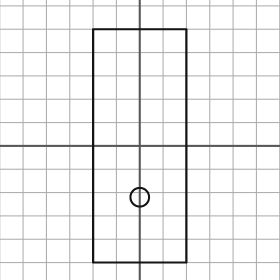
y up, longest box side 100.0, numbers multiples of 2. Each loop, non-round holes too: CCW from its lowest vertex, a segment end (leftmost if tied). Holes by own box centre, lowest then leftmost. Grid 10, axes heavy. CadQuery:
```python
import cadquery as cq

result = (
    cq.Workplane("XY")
    .moveTo(-20.0, -50.0)
    .lineTo(20.0, -50.0)
    .lineTo(20.0, 50.0)
    .lineTo(-20.0, 50.0)
    .close()
    .moveTo(0.0, -22.0)
    .circle(4.0)
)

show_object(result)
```